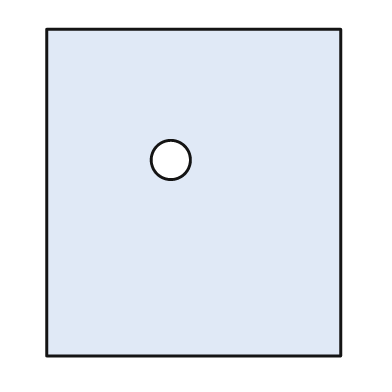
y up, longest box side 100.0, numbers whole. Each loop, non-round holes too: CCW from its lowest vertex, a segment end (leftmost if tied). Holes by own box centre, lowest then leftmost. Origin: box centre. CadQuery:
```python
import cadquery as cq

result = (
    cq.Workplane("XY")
    .moveTo(-45.0, -50.0)
    .lineTo(45.0, -50.0)
    .lineTo(45.0, 50.0)
    .lineTo(-45.0, 50.0)
    .close()
    .moveTo(-7.0, 10.0)
    .circle(6.0)
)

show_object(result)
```